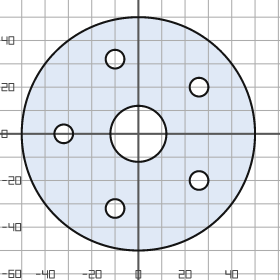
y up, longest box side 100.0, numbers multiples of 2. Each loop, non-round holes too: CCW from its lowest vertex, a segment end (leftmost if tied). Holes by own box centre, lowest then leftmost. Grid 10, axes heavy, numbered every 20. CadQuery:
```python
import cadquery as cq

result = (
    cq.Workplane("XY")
    .moveTo(0.0, 0.0)
    .circle(50.0)
    .moveTo(-10.0, -32.0)
    .circle(4.0)
    .moveTo(26.0, -20.0)
    .circle(4.0)
    .moveTo(-32.0, 0.0)
    .circle(4.0)
    .moveTo(0.0, 0.0)
    .circle(12.0)
    .moveTo(26.0, 20.0)
    .circle(4.0)
    .moveTo(-10.0, 32.0)
    .circle(4.0)
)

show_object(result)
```